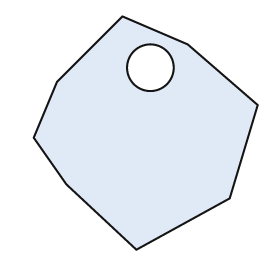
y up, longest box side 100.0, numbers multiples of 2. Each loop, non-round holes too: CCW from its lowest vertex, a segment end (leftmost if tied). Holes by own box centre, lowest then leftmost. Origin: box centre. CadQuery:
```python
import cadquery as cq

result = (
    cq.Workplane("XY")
    .moveTo(-4.0, -50.0)
    .lineTo(36.0, -28.0)
    .lineTo(48.0, 12.0)
    .lineTo(18.0, 38.0)
    .lineTo(-10.0, 50.0)
    .lineTo(-38.0, 22.0)
    .lineTo(-48.0, -2.0)
    .lineTo(-34.0, -22.0)
    .close()
    .moveTo(2.0, 28.0)
    .circle(10.0)
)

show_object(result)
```